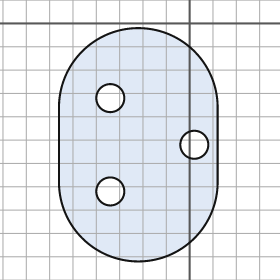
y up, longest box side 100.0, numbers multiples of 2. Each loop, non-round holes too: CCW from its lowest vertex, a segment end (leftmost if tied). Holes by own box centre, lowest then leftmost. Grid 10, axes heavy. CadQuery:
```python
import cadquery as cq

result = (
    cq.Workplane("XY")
    .moveTo(-56.0, -68.0)
    .threePointArc((-22.0, -102.0), (12.0, -68.0))
    .lineTo(12.0, -36.0)
    .threePointArc((-22.0, -2.0), (-56.0, -36.0))
    .close()
    .moveTo(-34.0, -72.0)
    .circle(6.0)
    .moveTo(2.0, -52.0)
    .circle(6.0)
    .moveTo(-34.0, -32.0)
    .circle(6.0)
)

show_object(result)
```